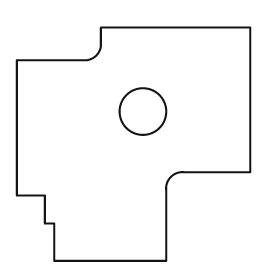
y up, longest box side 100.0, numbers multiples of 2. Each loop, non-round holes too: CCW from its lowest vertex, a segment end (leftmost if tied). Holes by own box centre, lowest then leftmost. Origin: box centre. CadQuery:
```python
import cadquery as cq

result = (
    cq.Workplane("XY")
    .moveTo(-34.0, -50.0)
    .lineTo(14.0, -50.0)
    .lineTo(14.0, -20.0)
    .threePointArc((16.0, -14.0), (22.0, -12.0))
    .lineTo(50.0, -12.0)
    .lineTo(50.0, 50.0)
    .lineTo(-14.0, 50.0)
    .lineTo(-14.0, 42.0)
    .threePointArc((-16.0, 38.0), (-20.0, 36.0))
    .lineTo(-50.0, 36.0)
    .lineTo(-50.0, -22.0)
    .lineTo(-38.0, -22.0)
    .lineTo(-38.0, -34.0)
    .lineTo(-34.0, -34.0)
    .close()
    .moveTo(4.0, 14.0)
    .circle(10.0)
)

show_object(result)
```